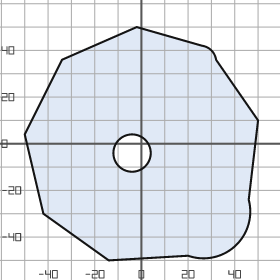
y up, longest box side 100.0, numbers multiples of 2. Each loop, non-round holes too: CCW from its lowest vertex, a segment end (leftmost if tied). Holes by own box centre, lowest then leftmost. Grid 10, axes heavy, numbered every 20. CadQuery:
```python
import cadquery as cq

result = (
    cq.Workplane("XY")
    .moveTo(-14.0, -50.0)
    .lineTo(20.0, -48.0)
    .threePointArc((40.0, -44.0), (46.0, -24.0))
    .lineTo(50.0, 10.0)
    .lineTo(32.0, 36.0)
    .threePointArc((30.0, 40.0), (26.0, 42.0))
    .lineTo(-2.0, 50.0)
    .lineTo(-34.0, 36.0)
    .lineTo(-50.0, 4.0)
    .lineTo(-42.0, -30.0)
    .close()
    .moveTo(-4.0, -4.0)
    .circle(8.0)
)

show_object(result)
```